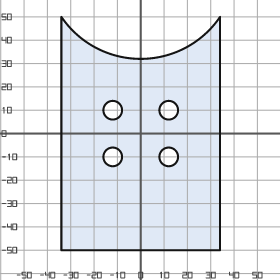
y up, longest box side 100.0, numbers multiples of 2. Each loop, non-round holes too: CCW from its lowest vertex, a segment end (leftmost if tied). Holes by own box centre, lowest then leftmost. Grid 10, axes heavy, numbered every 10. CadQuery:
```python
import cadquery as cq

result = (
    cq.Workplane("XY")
    .moveTo(-34.0, -50.0)
    .lineTo(34.0, -50.0)
    .lineTo(34.0, 50.0)
    .threePointArc((0.0, 32.0), (-34.0, 50.0))
    .close()
    .moveTo(-12.0, -10.0)
    .circle(4.0)
    .moveTo(12.0, -10.0)
    .circle(4.0)
    .moveTo(-12.0, 10.0)
    .circle(4.0)
    .moveTo(12.0, 10.0)
    .circle(4.0)
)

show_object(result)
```